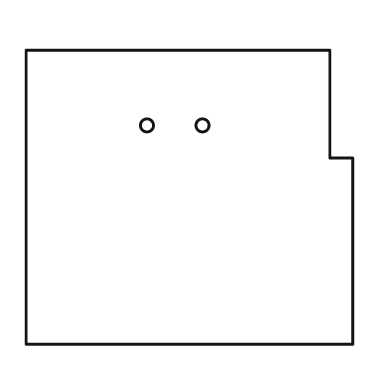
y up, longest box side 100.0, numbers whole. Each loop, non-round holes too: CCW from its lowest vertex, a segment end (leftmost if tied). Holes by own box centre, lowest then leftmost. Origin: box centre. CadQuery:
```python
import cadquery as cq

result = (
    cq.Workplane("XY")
    .moveTo(-50.0, -45.0)
    .lineTo(50.0, -45.0)
    .lineTo(50.0, 12.0)
    .lineTo(43.0, 12.0)
    .lineTo(43.0, 45.0)
    .lineTo(-50.0, 45.0)
    .close()
    .moveTo(-13.0, 22.0)
    .circle(2.0)
    .moveTo(4.0, 22.0)
    .circle(2.0)
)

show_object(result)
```